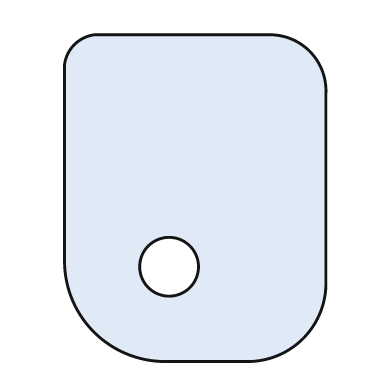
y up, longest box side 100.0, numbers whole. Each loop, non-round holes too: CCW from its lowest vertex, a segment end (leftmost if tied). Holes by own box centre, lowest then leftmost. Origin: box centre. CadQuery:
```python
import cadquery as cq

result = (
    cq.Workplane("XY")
    .moveTo(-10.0, -50.0)
    .lineTo(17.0, -50.0)
    .threePointArc((33.0, -43.0), (40.0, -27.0))
    .lineTo(40.0, 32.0)
    .threePointArc((35.0, 45.0), (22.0, 50.0))
    .lineTo(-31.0, 50.0)
    .threePointArc((-37.0, 47.0), (-40.0, 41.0))
    .lineTo(-40.0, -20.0)
    .threePointArc((-31.0, -41.0), (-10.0, -50.0))
    .close()
    .moveTo(-8.0, -21.0)
    .circle(9.0)
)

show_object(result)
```